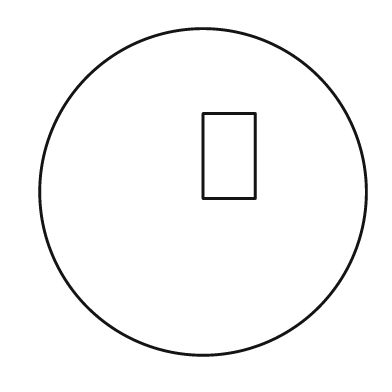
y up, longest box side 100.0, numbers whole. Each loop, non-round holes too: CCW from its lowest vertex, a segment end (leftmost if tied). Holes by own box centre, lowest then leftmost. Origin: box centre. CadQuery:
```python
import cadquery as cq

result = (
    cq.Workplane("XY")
    .moveTo(0.0, 0.0)
    .circle(50.0)
    .moveTo(0.0, -2.0)
    .lineTo(16.0, -2.0)
    .lineTo(16.0, 24.0)
    .lineTo(0.0, 24.0)
    .close()
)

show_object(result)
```